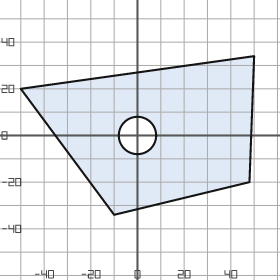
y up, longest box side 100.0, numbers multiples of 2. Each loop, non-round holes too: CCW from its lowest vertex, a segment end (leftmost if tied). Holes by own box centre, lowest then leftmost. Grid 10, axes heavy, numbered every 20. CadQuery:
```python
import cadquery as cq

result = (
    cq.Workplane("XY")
    .moveTo(-10.0, -34.0)
    .lineTo(48.0, -20.0)
    .lineTo(50.0, 34.0)
    .lineTo(-50.0, 20.0)
    .close()
    .moveTo(0.0, 0.0)
    .circle(8.0)
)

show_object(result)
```